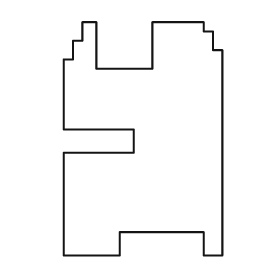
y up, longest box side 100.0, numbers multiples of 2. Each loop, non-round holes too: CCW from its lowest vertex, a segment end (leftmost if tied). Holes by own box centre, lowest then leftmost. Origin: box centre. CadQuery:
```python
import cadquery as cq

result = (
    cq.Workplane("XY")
    .moveTo(-34.0, -50.0)
    .lineTo(-10.0, -50.0)
    .lineTo(-10.0, -40.0)
    .lineTo(26.0, -40.0)
    .lineTo(26.0, -50.0)
    .lineTo(34.0, -50.0)
    .lineTo(34.0, 38.0)
    .lineTo(30.0, 38.0)
    .lineTo(30.0, 46.0)
    .lineTo(26.0, 46.0)
    .lineTo(26.0, 50.0)
    .lineTo(4.0, 50.0)
    .lineTo(4.0, 30.0)
    .lineTo(-20.0, 30.0)
    .lineTo(-20.0, 50.0)
    .lineTo(-26.0, 50.0)
    .lineTo(-26.0, 42.0)
    .lineTo(-30.0, 42.0)
    .lineTo(-30.0, 34.0)
    .lineTo(-34.0, 34.0)
    .lineTo(-34.0, 4.0)
    .lineTo(-4.0, 4.0)
    .lineTo(-4.0, -6.0)
    .lineTo(-34.0, -6.0)
    .close()
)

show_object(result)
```